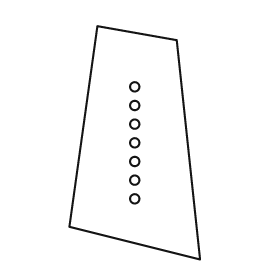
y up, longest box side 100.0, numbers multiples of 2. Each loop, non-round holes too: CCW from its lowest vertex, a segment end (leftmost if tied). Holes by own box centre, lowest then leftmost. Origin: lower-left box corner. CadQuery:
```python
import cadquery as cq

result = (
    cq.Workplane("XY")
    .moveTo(56.0, 0.0)
    .lineTo(46.0, 94.0)
    .lineTo(12.0, 100.0)
    .lineTo(0.0, 14.0)
    .close()
    .moveTo(28.0, 26.0)
    .circle(2.0)
    .moveTo(28.0, 34.0)
    .circle(2.0)
    .moveTo(28.0, 42.0)
    .circle(2.0)
    .moveTo(28.0, 50.0)
    .circle(2.0)
    .moveTo(28.0, 58.0)
    .circle(2.0)
    .moveTo(28.0, 66.0)
    .circle(2.0)
    .moveTo(28.0, 74.0)
    .circle(2.0)
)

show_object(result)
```